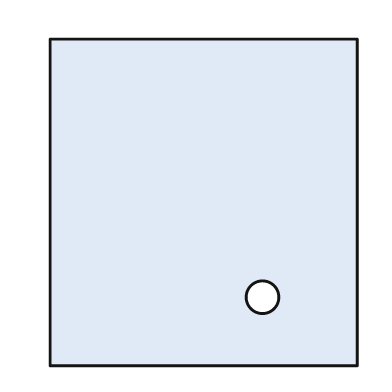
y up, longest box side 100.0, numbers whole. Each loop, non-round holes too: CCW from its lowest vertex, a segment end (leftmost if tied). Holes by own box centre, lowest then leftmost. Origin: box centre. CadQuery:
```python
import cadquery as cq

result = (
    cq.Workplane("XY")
    .moveTo(-47.0, -50.0)
    .lineTo(47.0, -50.0)
    .lineTo(47.0, 50.0)
    .lineTo(-47.0, 50.0)
    .close()
    .moveTo(18.0, -29.0)
    .circle(5.0)
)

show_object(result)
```